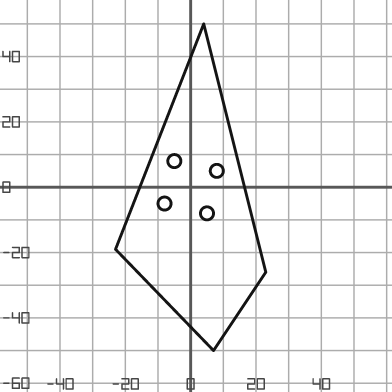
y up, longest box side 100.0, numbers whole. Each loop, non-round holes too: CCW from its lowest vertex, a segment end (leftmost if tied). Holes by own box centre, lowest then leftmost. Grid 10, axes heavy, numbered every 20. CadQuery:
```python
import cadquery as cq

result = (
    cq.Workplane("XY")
    .moveTo(7.0, -50.0)
    .lineTo(23.0, -26.0)
    .lineTo(4.0, 50.0)
    .lineTo(-23.0, -19.0)
    .close()
    .moveTo(5.0, -8.0)
    .circle(2.0)
    .moveTo(-8.0, -5.0)
    .circle(2.0)
    .moveTo(8.0, 5.0)
    .circle(2.0)
    .moveTo(-5.0, 8.0)
    .circle(2.0)
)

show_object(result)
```